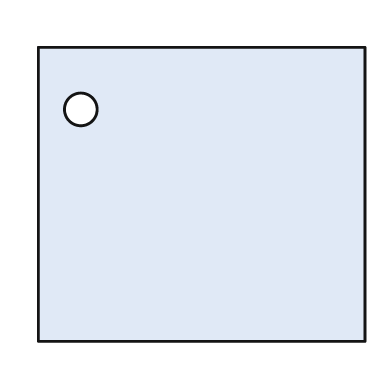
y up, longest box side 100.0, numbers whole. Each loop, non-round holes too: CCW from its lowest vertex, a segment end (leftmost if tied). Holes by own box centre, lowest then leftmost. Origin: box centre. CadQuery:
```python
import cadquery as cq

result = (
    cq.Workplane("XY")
    .moveTo(-50.0, -45.0)
    .lineTo(50.0, -45.0)
    .lineTo(50.0, 45.0)
    .lineTo(-50.0, 45.0)
    .close()
    .moveTo(-37.0, 26.0)
    .circle(5.0)
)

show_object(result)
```